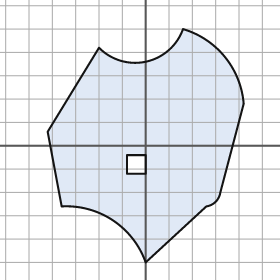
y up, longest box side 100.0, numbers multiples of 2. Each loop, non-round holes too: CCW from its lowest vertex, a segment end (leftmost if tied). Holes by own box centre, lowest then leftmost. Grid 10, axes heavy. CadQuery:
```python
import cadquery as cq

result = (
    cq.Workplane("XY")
    .moveTo(0.0, -50.0)
    .lineTo(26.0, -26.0)
    .threePointArc((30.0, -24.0), (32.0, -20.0))
    .lineTo(42.0, 18.0)
    .threePointArc((34.0, 38.0), (16.0, 50.0))
    .threePointArc((0.0, 36.0), (-20.0, 42.0))
    .lineTo(-42.0, 6.0)
    .lineTo(-36.0, -26.0)
    .threePointArc((-14.0, -32.0), (0.0, -50.0))
    .close()
    .moveTo(-8.0, -12.0)
    .lineTo(0.0, -12.0)
    .lineTo(0.0, -4.0)
    .lineTo(-8.0, -4.0)
    .close()
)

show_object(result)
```